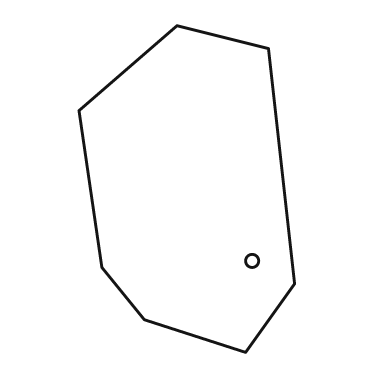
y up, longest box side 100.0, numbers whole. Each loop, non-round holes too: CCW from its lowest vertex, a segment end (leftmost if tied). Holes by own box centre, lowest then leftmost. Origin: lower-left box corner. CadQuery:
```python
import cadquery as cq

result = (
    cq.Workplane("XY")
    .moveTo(51.0, 0.0)
    .lineTo(66.0, 21.0)
    .lineTo(58.0, 93.0)
    .lineTo(30.0, 100.0)
    .lineTo(0.0, 74.0)
    .lineTo(7.0, 26.0)
    .lineTo(20.0, 10.0)
    .close()
    .moveTo(53.0, 28.0)
    .circle(2.0)
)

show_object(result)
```